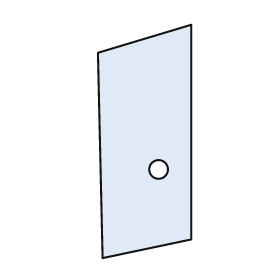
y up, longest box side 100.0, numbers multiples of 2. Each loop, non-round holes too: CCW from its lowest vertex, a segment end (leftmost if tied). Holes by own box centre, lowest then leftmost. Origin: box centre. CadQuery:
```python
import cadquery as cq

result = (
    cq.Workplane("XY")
    .moveTo(-18.0, -50.0)
    .lineTo(20.0, -42.0)
    .lineTo(20.0, 50.0)
    .lineTo(-20.0, 38.0)
    .close()
    .moveTo(6.0, -12.0)
    .circle(4.0)
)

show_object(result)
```